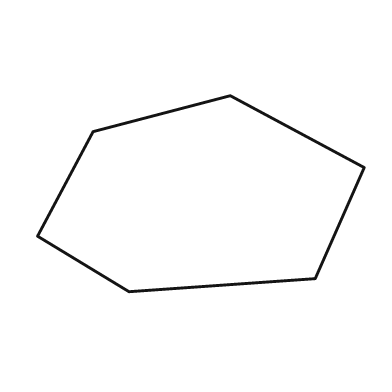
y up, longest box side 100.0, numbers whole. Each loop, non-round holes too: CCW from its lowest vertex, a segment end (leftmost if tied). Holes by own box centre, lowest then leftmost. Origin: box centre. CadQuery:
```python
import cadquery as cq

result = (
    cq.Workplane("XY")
    .moveTo(-22.0, -30.0)
    .lineTo(35.0, -26.0)
    .lineTo(50.0, 8.0)
    .lineTo(9.0, 30.0)
    .lineTo(-33.0, 19.0)
    .lineTo(-50.0, -13.0)
    .close()
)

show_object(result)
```